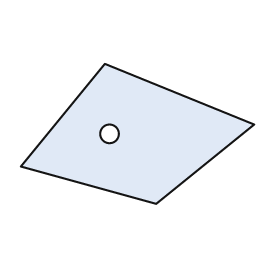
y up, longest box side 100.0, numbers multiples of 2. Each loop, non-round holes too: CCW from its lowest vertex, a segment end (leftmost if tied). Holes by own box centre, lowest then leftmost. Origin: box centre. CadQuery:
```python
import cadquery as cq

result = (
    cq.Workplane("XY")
    .moveTo(8.0, -30.0)
    .lineTo(50.0, 4.0)
    .lineTo(-14.0, 30.0)
    .lineTo(-50.0, -14.0)
    .close()
    .moveTo(-12.0, 0.0)
    .circle(4.0)
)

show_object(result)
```